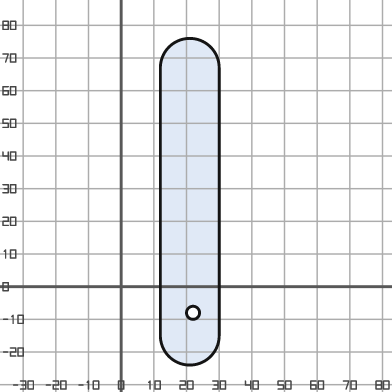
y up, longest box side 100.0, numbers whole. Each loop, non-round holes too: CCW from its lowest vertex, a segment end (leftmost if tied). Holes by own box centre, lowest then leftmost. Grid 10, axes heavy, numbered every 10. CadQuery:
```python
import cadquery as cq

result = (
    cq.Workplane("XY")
    .moveTo(12.0, -15.0)
    .threePointArc((21.0, -24.0), (30.0, -15.0))
    .lineTo(30.0, 67.0)
    .threePointArc((21.0, 76.0), (12.0, 67.0))
    .close()
    .moveTo(22.0, -8.0)
    .circle(2.0)
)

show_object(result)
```